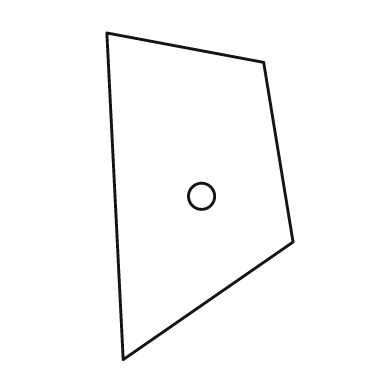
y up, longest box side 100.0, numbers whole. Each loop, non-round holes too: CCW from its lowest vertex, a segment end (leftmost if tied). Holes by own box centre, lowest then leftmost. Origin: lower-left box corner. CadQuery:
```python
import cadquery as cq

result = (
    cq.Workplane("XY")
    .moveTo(5.0, 0.0)
    .lineTo(57.0, 36.0)
    .lineTo(48.0, 91.0)
    .lineTo(0.0, 100.0)
    .close()
    .moveTo(29.0, 50.0)
    .circle(4.0)
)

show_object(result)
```